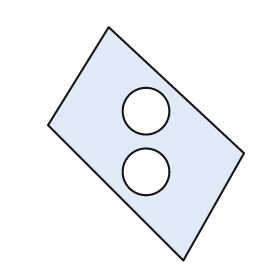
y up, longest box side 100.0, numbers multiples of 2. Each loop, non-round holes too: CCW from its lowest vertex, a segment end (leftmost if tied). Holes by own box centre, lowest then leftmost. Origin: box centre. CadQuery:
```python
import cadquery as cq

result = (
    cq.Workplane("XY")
    .moveTo(16.0, -50.0)
    .lineTo(42.0, -4.0)
    .lineTo(-16.0, 50.0)
    .lineTo(-42.0, 8.0)
    .close()
    .moveTo(0.0, -12.0)
    .circle(10.0)
    .moveTo(0.0, 14.0)
    .circle(10.0)
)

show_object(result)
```